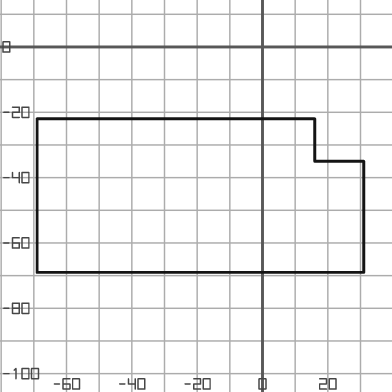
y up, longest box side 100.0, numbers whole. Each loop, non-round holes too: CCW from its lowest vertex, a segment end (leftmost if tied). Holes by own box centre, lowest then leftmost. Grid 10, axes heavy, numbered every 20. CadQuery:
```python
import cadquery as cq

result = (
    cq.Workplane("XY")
    .moveTo(-69.0, -69.0)
    .lineTo(31.0, -69.0)
    .lineTo(31.0, -35.0)
    .lineTo(16.0, -35.0)
    .lineTo(16.0, -22.0)
    .lineTo(-69.0, -22.0)
    .close()
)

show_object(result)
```